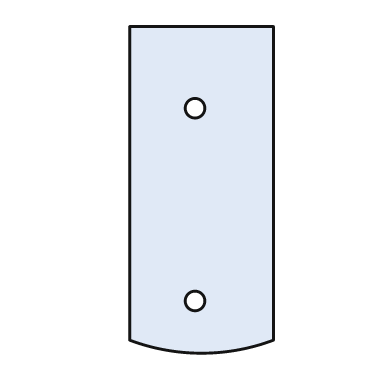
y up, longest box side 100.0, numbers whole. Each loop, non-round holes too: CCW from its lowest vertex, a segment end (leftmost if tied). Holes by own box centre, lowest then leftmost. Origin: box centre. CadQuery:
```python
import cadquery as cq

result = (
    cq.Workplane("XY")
    .moveTo(-22.0, -46.0)
    .threePointArc((0.0, -50.0), (22.0, -46.0))
    .lineTo(22.0, 50.0)
    .lineTo(-22.0, 50.0)
    .close()
    .moveTo(-2.0, -34.0)
    .circle(3.0)
    .moveTo(-2.0, 25.0)
    .circle(3.0)
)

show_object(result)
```